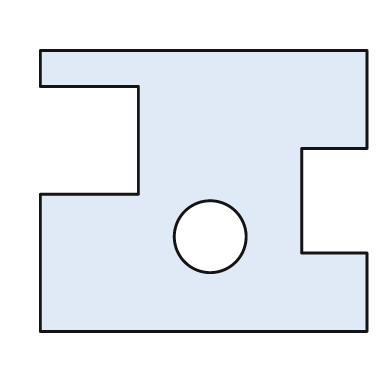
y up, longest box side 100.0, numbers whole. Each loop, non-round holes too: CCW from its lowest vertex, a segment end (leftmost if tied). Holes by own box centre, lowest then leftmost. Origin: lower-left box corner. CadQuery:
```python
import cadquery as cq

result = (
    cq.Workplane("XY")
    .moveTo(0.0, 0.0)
    .lineTo(100.0, 0.0)
    .lineTo(100.0, 24.0)
    .lineTo(80.0, 24.0)
    .lineTo(80.0, 56.0)
    .lineTo(100.0, 56.0)
    .lineTo(100.0, 86.0)
    .lineTo(0.0, 86.0)
    .lineTo(0.0, 75.0)
    .lineTo(30.0, 75.0)
    .lineTo(30.0, 42.0)
    .lineTo(0.0, 42.0)
    .close()
    .moveTo(52.0, 29.0)
    .circle(11.0)
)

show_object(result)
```